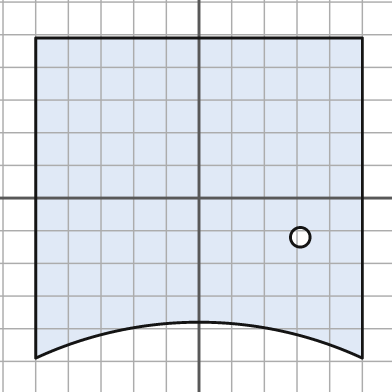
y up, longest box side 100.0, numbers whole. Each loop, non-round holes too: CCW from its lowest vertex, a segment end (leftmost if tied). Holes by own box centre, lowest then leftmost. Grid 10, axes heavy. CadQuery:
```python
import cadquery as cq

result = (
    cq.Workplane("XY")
    .moveTo(-50.0, -49.0)
    .threePointArc((0.0, -38.0), (50.0, -49.0))
    .lineTo(50.0, 49.0)
    .lineTo(-50.0, 49.0)
    .close()
    .moveTo(31.0, -12.0)
    .circle(3.0)
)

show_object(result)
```